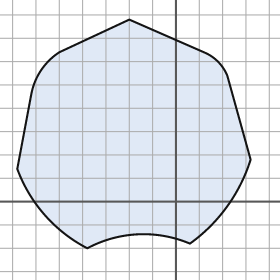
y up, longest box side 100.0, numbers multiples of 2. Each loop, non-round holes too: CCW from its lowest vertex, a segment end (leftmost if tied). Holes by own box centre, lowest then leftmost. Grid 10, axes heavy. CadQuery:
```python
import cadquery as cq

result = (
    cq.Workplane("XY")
    .moveTo(-38.0, -20.0)
    .threePointArc((-16.0, -14.0), (6.0, -18.0))
    .threePointArc((22.0, -2.0), (32.0, 18.0))
    .lineTo(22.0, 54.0)
    .threePointArc((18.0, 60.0), (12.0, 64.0))
    .lineTo(-20.0, 78.0)
    .lineTo(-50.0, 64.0)
    .threePointArc((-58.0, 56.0), (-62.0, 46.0))
    .lineTo(-68.0, 14.0)
    .threePointArc((-56.0, -6.0), (-38.0, -20.0))
    .close()
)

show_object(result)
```